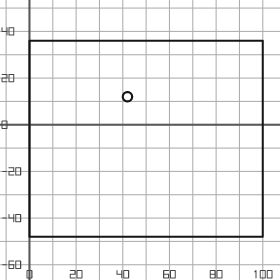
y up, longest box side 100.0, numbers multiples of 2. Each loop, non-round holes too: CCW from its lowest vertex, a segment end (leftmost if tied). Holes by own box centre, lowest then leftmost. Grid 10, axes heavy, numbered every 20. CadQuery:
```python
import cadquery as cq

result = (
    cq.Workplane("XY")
    .moveTo(0.0, -48.0)
    .lineTo(100.0, -48.0)
    .lineTo(100.0, 36.0)
    .lineTo(0.0, 36.0)
    .close()
    .moveTo(42.0, 12.0)
    .circle(2.0)
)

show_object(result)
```